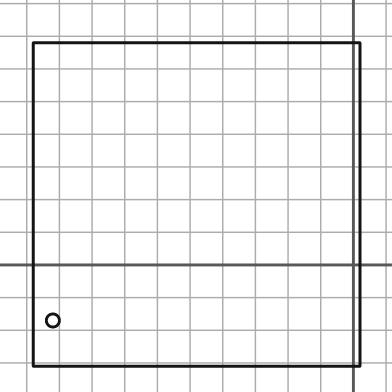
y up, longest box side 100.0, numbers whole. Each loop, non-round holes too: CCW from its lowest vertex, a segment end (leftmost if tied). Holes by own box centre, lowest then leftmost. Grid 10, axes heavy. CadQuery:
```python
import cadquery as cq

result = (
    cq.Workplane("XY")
    .moveTo(-98.0, -31.0)
    .lineTo(2.0, -31.0)
    .lineTo(2.0, 68.0)
    .lineTo(-98.0, 68.0)
    .close()
    .moveTo(-92.0, -17.0)
    .circle(2.0)
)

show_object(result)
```